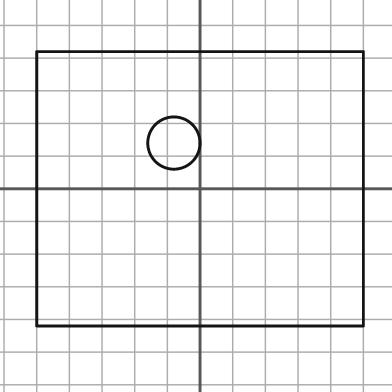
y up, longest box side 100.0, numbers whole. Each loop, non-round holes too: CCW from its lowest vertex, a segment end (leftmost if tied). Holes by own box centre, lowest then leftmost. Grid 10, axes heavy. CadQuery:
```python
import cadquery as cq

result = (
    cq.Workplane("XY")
    .moveTo(-50.0, -42.0)
    .lineTo(50.0, -42.0)
    .lineTo(50.0, 42.0)
    .lineTo(-50.0, 42.0)
    .close()
    .moveTo(-8.0, 14.0)
    .circle(8.0)
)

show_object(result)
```